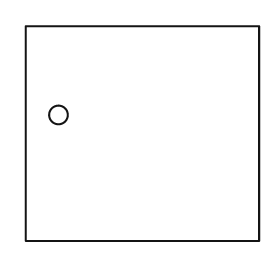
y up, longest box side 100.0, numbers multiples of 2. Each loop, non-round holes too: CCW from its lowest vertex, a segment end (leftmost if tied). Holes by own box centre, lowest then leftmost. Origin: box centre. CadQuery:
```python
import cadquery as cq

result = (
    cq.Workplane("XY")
    .moveTo(-50.0, -46.0)
    .lineTo(50.0, -46.0)
    .lineTo(50.0, 46.0)
    .lineTo(-50.0, 46.0)
    .close()
    .moveTo(-36.0, 8.0)
    .circle(4.0)
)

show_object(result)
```